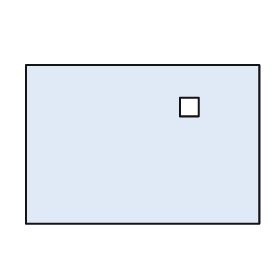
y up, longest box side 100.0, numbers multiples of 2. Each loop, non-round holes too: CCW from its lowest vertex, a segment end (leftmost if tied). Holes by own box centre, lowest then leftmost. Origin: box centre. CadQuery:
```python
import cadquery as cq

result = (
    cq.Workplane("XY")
    .moveTo(-50.0, -34.0)
    .lineTo(50.0, -34.0)
    .lineTo(50.0, 34.0)
    .lineTo(-50.0, 34.0)
    .close()
    .moveTo(16.0, 12.0)
    .lineTo(24.0, 12.0)
    .lineTo(24.0, 20.0)
    .lineTo(16.0, 20.0)
    .close()
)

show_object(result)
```